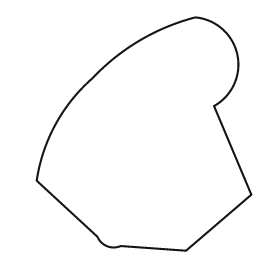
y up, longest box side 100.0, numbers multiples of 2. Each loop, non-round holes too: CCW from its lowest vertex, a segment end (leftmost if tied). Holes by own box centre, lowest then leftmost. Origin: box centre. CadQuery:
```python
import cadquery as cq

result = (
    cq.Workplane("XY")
    .moveTo(18.0, -50.0)
    .lineTo(46.0, -26.0)
    .lineTo(30.0, 12.0)
    .threePointArc((40.0, 34.0), (22.0, 50.0))
    .threePointArc((-2.0, 40.0), (-22.0, 24.0))
    .threePointArc((-38.0, 4.0), (-46.0, -20.0))
    .lineTo(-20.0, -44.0)
    .threePointArc((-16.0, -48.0), (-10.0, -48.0))
    .close()
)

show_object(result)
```